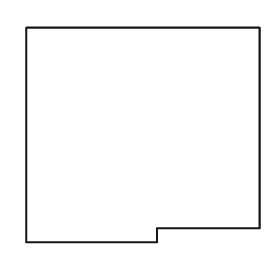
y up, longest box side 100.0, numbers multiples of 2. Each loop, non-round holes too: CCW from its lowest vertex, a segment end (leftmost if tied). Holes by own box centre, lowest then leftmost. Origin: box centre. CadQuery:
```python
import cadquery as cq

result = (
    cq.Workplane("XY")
    .moveTo(-50.0, -46.0)
    .lineTo(6.0, -46.0)
    .lineTo(6.0, -40.0)
    .lineTo(50.0, -40.0)
    .lineTo(50.0, 46.0)
    .lineTo(-50.0, 46.0)
    .close()
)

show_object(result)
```